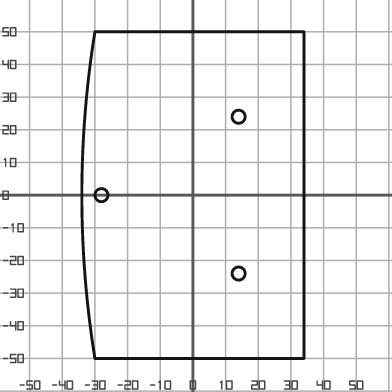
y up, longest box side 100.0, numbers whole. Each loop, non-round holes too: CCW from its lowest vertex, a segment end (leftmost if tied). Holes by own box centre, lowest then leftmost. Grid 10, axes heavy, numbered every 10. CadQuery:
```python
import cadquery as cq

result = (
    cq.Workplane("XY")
    .moveTo(-30.0, -50.0)
    .lineTo(34.0, -50.0)
    .lineTo(34.0, 50.0)
    .lineTo(-30.0, 50.0)
    .threePointArc((-34.0, 0.0), (-30.0, -50.0))
    .close()
    .moveTo(14.0, -24.0)
    .circle(2.0)
    .moveTo(-28.0, 0.0)
    .circle(2.0)
    .moveTo(14.0, 24.0)
    .circle(2.0)
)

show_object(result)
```